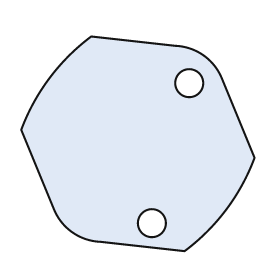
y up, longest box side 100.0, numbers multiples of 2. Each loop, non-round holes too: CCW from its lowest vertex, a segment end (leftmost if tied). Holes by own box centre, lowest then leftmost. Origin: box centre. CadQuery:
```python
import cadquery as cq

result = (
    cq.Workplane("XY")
    .moveTo(20.0, -46.0)
    .threePointArc((38.0, -28.0), (50.0, -6.0))
    .lineTo(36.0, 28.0)
    .threePointArc((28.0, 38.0), (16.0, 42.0))
    .lineTo(-20.0, 46.0)
    .threePointArc((-38.0, 28.0), (-50.0, 6.0))
    .lineTo(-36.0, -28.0)
    .threePointArc((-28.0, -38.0), (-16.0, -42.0))
    .close()
    .moveTo(6.0, -34.0)
    .circle(6.0)
    .moveTo(22.0, 26.0)
    .circle(6.0)
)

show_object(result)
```